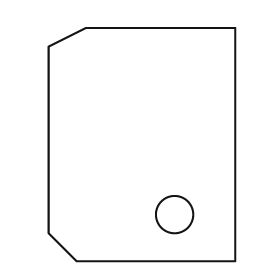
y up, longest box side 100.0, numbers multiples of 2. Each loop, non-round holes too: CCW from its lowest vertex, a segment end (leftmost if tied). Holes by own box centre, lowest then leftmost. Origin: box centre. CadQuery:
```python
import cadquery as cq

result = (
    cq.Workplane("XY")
    .moveTo(-28.0, -50.0)
    .lineTo(40.0, -50.0)
    .lineTo(40.0, 50.0)
    .lineTo(-24.0, 50.0)
    .lineTo(-40.0, 42.0)
    .lineTo(-40.0, -38.0)
    .close()
    .moveTo(14.0, -30.0)
    .circle(8.0)
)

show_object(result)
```